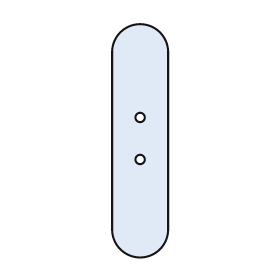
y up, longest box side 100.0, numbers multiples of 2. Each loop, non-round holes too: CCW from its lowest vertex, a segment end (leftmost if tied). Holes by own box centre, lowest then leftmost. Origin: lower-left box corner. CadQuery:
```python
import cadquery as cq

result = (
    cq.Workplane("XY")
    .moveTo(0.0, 12.0)
    .threePointArc((12.0, 0.0), (24.0, 12.0))
    .lineTo(24.0, 88.0)
    .threePointArc((12.0, 100.0), (0.0, 88.0))
    .close()
    .moveTo(12.0, 42.0)
    .circle(2.0)
    .moveTo(12.0, 60.0)
    .circle(2.0)
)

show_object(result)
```